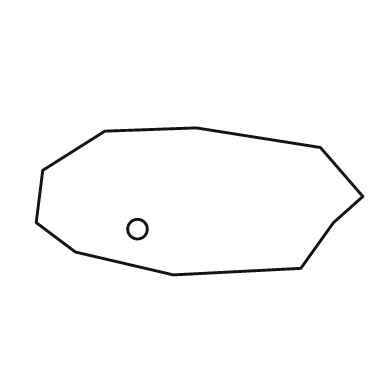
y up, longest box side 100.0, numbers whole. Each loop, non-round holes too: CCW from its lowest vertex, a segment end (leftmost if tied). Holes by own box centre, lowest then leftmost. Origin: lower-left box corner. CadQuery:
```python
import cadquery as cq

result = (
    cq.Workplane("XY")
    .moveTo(42.0, 0.0)
    .lineTo(81.0, 2.0)
    .lineTo(91.0, 16.0)
    .lineTo(100.0, 24.0)
    .lineTo(87.0, 39.0)
    .lineTo(49.0, 45.0)
    .lineTo(21.0, 44.0)
    .lineTo(2.0, 32.0)
    .lineTo(0.0, 16.0)
    .lineTo(12.0, 7.0)
    .close()
    .moveTo(31.0, 14.0)
    .circle(3.0)
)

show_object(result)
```